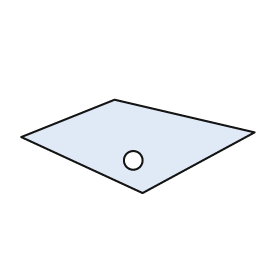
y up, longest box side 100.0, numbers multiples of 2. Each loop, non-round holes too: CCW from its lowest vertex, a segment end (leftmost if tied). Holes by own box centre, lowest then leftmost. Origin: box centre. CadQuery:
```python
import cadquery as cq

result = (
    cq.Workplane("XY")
    .moveTo(2.0, -20.0)
    .lineTo(50.0, 6.0)
    .lineTo(-10.0, 20.0)
    .lineTo(-50.0, 4.0)
    .close()
    .moveTo(-2.0, -6.0)
    .circle(4.0)
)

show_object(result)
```